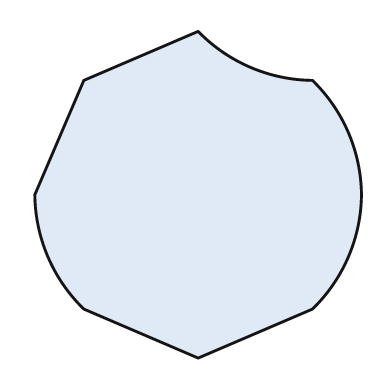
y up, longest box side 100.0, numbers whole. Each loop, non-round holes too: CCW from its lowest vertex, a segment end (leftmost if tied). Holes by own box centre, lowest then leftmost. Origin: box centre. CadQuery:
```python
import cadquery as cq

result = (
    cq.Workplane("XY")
    .moveTo(0.0, -50.0)
    .lineTo(35.0, -35.0)
    .threePointArc((46.0, -19.0), (50.0, 0.0))
    .threePointArc((46.0, 19.0), (35.0, 35.0))
    .threePointArc((16.0, 39.0), (0.0, 50.0))
    .lineTo(-35.0, 35.0)
    .lineTo(-50.0, 0.0)
    .threePointArc((-46.0, -19.0), (-35.0, -35.0))
    .close()
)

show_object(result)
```